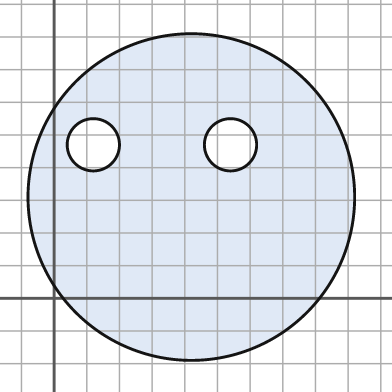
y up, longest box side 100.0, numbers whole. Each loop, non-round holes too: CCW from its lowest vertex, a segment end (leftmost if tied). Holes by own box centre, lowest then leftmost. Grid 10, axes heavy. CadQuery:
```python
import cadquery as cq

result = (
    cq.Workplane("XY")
    .moveTo(42.0, 31.0)
    .circle(50.0)
    .moveTo(12.0, 47.0)
    .circle(8.0)
    .moveTo(54.0, 47.0)
    .circle(8.0)
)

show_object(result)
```